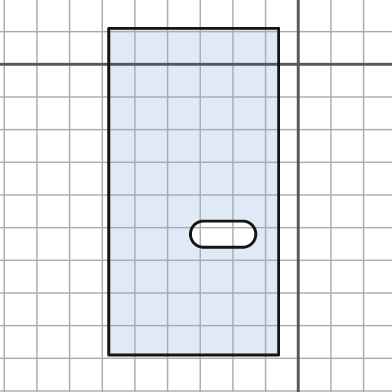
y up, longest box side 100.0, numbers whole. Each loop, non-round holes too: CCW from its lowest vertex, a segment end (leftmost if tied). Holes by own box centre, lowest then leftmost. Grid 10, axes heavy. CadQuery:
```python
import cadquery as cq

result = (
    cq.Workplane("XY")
    .moveTo(-58.0, -89.0)
    .lineTo(-6.0, -89.0)
    .lineTo(-6.0, 11.0)
    .lineTo(-58.0, 11.0)
    .close()
    .moveTo(-29.0, -56.0)
    .lineTo(-17.0, -56.0)
    .threePointArc((-13.0, -52.0), (-17.0, -48.0))
    .lineTo(-29.0, -48.0)
    .threePointArc((-33.0, -52.0), (-29.0, -56.0))
    .close()
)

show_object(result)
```